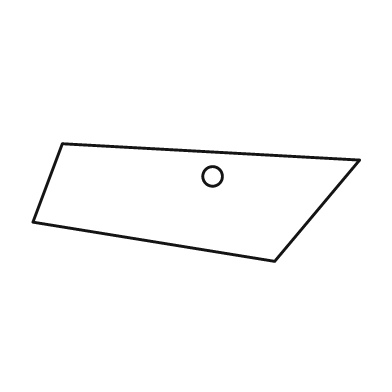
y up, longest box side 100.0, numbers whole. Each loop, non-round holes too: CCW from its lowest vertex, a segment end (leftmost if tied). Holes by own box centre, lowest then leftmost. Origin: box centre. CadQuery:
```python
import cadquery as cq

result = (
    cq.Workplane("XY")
    .moveTo(24.0, -18.0)
    .lineTo(50.0, 13.0)
    .lineTo(-41.0, 18.0)
    .lineTo(-50.0, -6.0)
    .close()
    .moveTo(5.0, 8.0)
    .circle(3.0)
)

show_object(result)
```